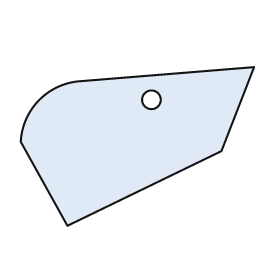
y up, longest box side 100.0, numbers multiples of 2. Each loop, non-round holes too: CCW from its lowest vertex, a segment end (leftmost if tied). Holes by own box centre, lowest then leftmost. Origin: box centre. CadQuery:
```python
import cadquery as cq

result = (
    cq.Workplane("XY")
    .moveTo(-30.0, -34.0)
    .lineTo(36.0, -2.0)
    .lineTo(50.0, 34.0)
    .lineTo(-24.0, 28.0)
    .threePointArc((-42.0, 20.0), (-50.0, 2.0))
    .close()
    .moveTo(6.0, 20.0)
    .circle(4.0)
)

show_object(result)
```